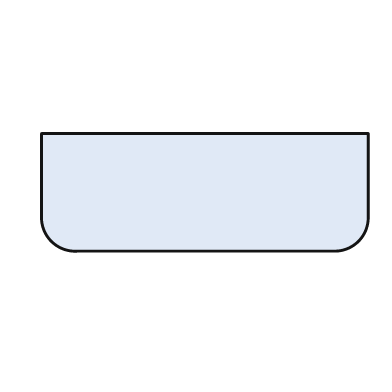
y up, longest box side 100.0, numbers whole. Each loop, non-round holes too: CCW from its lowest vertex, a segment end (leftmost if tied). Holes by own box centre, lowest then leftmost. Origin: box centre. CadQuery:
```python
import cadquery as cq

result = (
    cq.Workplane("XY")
    .moveTo(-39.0, -18.0)
    .lineTo(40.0, -18.0)
    .threePointArc((47.0, -15.0), (50.0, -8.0))
    .lineTo(50.0, 18.0)
    .lineTo(-50.0, 18.0)
    .lineTo(-50.0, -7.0)
    .threePointArc((-47.0, -15.0), (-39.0, -18.0))
    .close()
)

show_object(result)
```